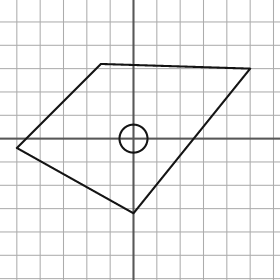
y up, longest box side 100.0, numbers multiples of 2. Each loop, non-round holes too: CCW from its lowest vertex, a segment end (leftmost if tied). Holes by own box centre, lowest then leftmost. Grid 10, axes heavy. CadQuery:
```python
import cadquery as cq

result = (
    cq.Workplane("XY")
    .moveTo(0.0, -32.0)
    .lineTo(50.0, 30.0)
    .lineTo(-14.0, 32.0)
    .lineTo(-50.0, -4.0)
    .close()
    .moveTo(0.0, 0.0)
    .circle(6.0)
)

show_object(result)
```